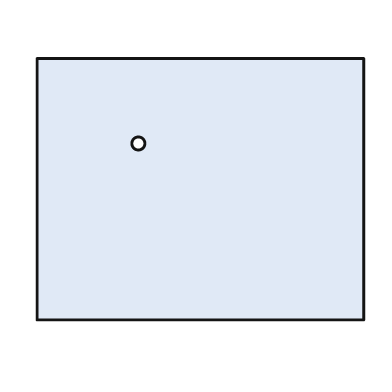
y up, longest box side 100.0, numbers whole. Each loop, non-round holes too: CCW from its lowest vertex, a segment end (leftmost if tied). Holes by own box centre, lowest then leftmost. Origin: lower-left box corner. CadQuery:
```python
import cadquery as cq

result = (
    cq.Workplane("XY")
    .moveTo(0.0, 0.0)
    .lineTo(100.0, 0.0)
    .lineTo(100.0, 80.0)
    .lineTo(0.0, 80.0)
    .close()
    .moveTo(31.0, 54.0)
    .circle(2.0)
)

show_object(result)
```